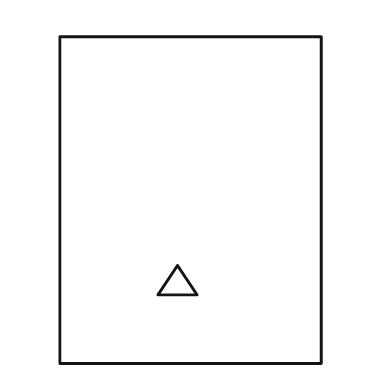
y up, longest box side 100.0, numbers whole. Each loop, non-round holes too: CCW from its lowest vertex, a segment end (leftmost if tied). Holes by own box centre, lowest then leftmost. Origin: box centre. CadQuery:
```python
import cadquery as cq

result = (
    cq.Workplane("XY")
    .moveTo(-40.0, -50.0)
    .lineTo(40.0, -50.0)
    .lineTo(40.0, 50.0)
    .lineTo(-40.0, 50.0)
    .close()
    .moveTo(-10.0, -29.0)
    .lineTo(2.0, -29.0)
    .lineTo(-4.0, -20.0)
    .close()
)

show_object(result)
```